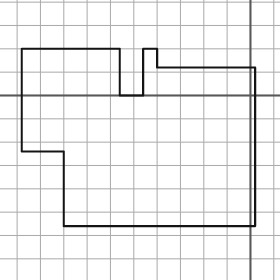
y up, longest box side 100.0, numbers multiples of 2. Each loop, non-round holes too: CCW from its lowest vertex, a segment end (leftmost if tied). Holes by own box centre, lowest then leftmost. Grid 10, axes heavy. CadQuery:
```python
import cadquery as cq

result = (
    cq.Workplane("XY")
    .moveTo(-80.0, -56.0)
    .lineTo(2.0, -56.0)
    .lineTo(2.0, 12.0)
    .lineTo(-40.0, 12.0)
    .lineTo(-40.0, 20.0)
    .lineTo(-46.0, 20.0)
    .lineTo(-46.0, 0.0)
    .lineTo(-56.0, 0.0)
    .lineTo(-56.0, 20.0)
    .lineTo(-98.0, 20.0)
    .lineTo(-98.0, -24.0)
    .lineTo(-80.0, -24.0)
    .close()
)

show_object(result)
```